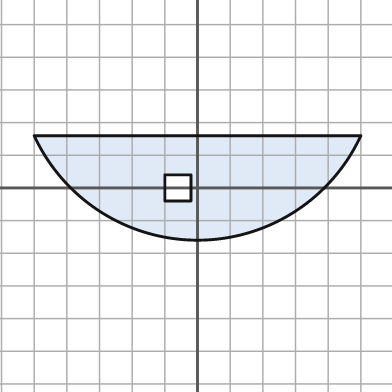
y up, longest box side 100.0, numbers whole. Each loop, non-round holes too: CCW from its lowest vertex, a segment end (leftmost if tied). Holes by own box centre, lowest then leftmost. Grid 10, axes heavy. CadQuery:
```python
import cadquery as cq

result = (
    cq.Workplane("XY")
    .moveTo(-50.0, 16.0)
    .threePointArc((0.0, -16.0), (50.0, 16.0))
    .close()
    .moveTo(-10.0, -4.0)
    .lineTo(-2.0, -4.0)
    .lineTo(-2.0, 4.0)
    .lineTo(-10.0, 4.0)
    .close()
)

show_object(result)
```